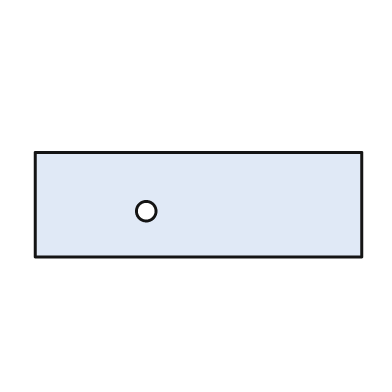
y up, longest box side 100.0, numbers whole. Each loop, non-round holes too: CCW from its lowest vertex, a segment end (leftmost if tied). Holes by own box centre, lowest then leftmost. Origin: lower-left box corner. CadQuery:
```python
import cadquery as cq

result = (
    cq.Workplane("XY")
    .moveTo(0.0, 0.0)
    .lineTo(100.0, 0.0)
    .lineTo(100.0, 32.0)
    .lineTo(0.0, 32.0)
    .close()
    .moveTo(34.0, 14.0)
    .circle(3.0)
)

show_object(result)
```